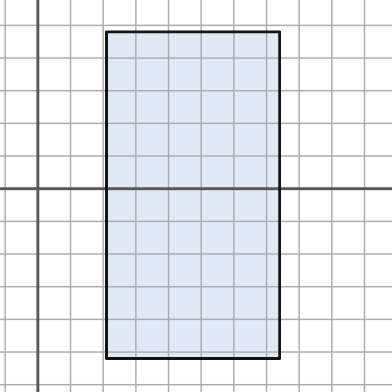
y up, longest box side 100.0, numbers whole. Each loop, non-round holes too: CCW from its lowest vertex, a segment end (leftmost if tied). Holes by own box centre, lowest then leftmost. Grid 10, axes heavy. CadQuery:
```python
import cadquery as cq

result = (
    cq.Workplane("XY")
    .moveTo(21.0, -52.0)
    .lineTo(74.0, -52.0)
    .lineTo(74.0, 48.0)
    .lineTo(21.0, 48.0)
    .close()
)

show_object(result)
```